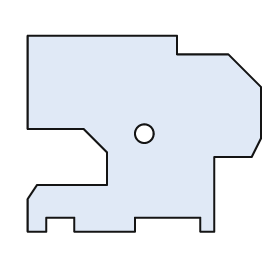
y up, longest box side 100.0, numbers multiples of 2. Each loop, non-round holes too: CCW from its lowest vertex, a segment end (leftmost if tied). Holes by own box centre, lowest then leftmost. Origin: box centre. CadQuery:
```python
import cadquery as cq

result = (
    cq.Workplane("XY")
    .moveTo(-50.0, -42.0)
    .lineTo(-42.0, -42.0)
    .lineTo(-42.0, -36.0)
    .lineTo(-30.0, -36.0)
    .lineTo(-30.0, -42.0)
    .lineTo(-4.0, -42.0)
    .lineTo(-4.0, -36.0)
    .lineTo(24.0, -36.0)
    .lineTo(24.0, -42.0)
    .lineTo(30.0, -42.0)
    .lineTo(30.0, -10.0)
    .lineTo(46.0, -10.0)
    .lineTo(50.0, -2.0)
    .lineTo(50.0, 20.0)
    .lineTo(36.0, 34.0)
    .lineTo(14.0, 34.0)
    .lineTo(14.0, 42.0)
    .lineTo(-50.0, 42.0)
    .lineTo(-50.0, 2.0)
    .lineTo(-26.0, 2.0)
    .lineTo(-16.0, -8.0)
    .lineTo(-16.0, -22.0)
    .lineTo(-46.0, -22.0)
    .lineTo(-50.0, -28.0)
    .close()
    .moveTo(0.0, 0.0)
    .circle(4.0)
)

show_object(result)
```